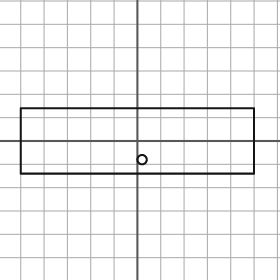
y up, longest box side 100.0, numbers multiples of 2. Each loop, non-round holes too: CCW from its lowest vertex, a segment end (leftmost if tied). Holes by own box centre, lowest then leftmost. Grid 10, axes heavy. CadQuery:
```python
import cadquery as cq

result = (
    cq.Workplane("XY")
    .moveTo(-50.0, -14.0)
    .lineTo(50.0, -14.0)
    .lineTo(50.0, 14.0)
    .lineTo(-50.0, 14.0)
    .close()
    .moveTo(2.0, -8.0)
    .circle(2.0)
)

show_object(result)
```